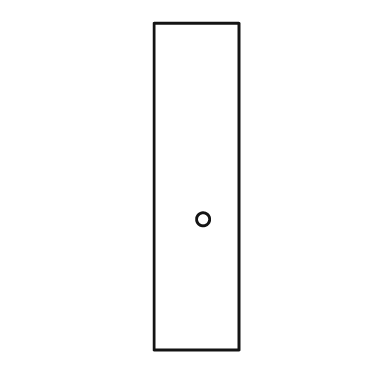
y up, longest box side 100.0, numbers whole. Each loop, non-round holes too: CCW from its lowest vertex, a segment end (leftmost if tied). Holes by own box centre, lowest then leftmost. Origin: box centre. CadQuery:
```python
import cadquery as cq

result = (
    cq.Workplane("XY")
    .moveTo(-13.0, -50.0)
    .lineTo(13.0, -50.0)
    .lineTo(13.0, 50.0)
    .lineTo(-13.0, 50.0)
    .close()
    .moveTo(2.0, -10.0)
    .circle(2.0)
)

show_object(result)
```